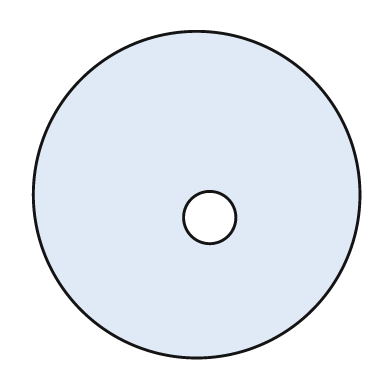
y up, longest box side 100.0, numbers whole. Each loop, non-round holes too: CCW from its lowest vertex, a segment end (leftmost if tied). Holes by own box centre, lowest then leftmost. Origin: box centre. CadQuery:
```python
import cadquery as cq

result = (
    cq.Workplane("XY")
    .moveTo(0.0, 0.0)
    .circle(50.0)
    .moveTo(4.0, -7.0)
    .circle(8.0)
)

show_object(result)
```